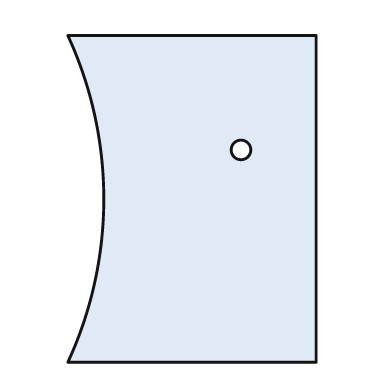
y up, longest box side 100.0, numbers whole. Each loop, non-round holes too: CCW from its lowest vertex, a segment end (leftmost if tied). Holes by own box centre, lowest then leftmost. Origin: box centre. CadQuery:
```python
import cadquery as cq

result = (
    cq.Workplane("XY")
    .moveTo(-38.0, -50.0)
    .lineTo(38.0, -50.0)
    .lineTo(38.0, 50.0)
    .lineTo(-38.0, 50.0)
    .threePointArc((-27.0, 0.0), (-38.0, -50.0))
    .close()
    .moveTo(15.0, 15.0)
    .circle(3.0)
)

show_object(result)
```